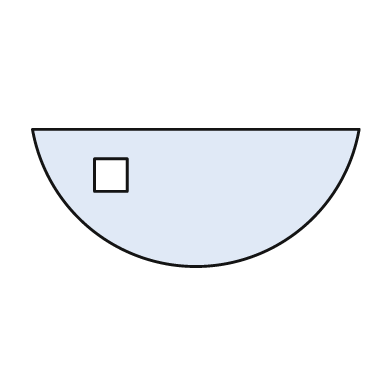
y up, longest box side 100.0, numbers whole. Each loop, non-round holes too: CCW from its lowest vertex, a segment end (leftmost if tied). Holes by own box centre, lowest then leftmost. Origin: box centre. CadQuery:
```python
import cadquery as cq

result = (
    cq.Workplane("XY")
    .moveTo(-50.0, 21.0)
    .threePointArc((0.0, -21.0), (50.0, 21.0))
    .close()
    .moveTo(-31.0, 2.0)
    .lineTo(-21.0, 2.0)
    .lineTo(-21.0, 12.0)
    .lineTo(-31.0, 12.0)
    .close()
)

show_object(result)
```